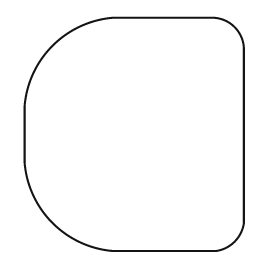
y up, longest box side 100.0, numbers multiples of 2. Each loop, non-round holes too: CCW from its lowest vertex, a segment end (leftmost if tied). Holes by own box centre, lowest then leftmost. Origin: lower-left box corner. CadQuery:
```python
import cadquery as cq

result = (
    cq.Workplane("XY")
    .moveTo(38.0, 0.0)
    .lineTo(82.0, 0.0)
    .threePointArc((90.0, 4.0), (94.0, 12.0))
    .lineTo(94.0, 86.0)
    .threePointArc((90.0, 96.0), (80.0, 100.0))
    .lineTo(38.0, 100.0)
    .threePointArc((12.0, 88.0), (0.0, 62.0))
    .lineTo(0.0, 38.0)
    .threePointArc((12.0, 12.0), (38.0, 0.0))
    .close()
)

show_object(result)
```